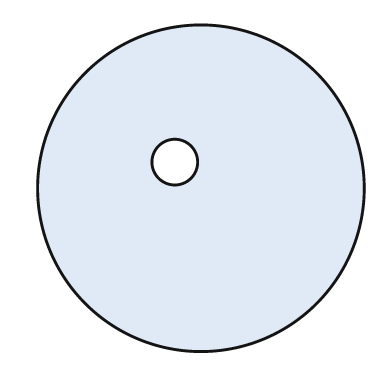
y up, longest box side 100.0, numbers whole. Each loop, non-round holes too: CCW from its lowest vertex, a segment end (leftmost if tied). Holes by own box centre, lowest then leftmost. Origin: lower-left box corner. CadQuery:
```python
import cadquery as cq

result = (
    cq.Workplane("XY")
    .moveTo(50.0, 50.0)
    .circle(50.0)
    .moveTo(42.0, 58.0)
    .circle(7.0)
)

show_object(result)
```